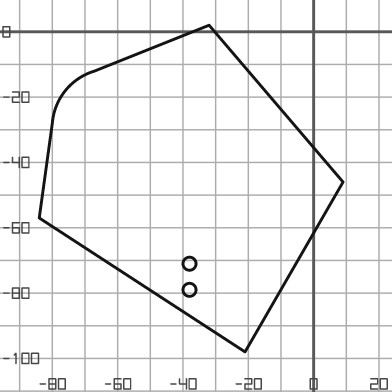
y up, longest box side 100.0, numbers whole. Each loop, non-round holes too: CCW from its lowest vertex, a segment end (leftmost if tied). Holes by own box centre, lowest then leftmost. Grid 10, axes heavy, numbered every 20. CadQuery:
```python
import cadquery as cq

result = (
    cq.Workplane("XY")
    .moveTo(-21.0, -98.0)
    .lineTo(9.0, -46.0)
    .lineTo(-32.0, 2.0)
    .lineTo(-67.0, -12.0)
    .threePointArc((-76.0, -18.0), (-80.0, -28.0))
    .lineTo(-84.0, -57.0)
    .close()
    .moveTo(-38.0, -79.0)
    .circle(2.0)
    .moveTo(-38.0, -71.0)
    .circle(2.0)
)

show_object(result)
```